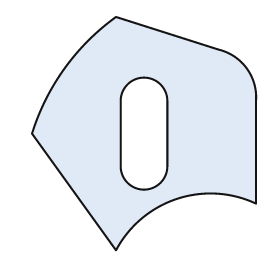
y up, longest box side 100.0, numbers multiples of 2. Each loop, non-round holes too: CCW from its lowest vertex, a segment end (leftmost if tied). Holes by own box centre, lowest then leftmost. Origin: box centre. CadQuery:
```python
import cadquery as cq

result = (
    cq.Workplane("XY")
    .moveTo(-12.0, -50.0)
    .threePointArc((14.0, -28.0), (48.0, -30.0))
    .lineTo(48.0, 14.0)
    .threePointArc((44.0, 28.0), (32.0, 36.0))
    .lineTo(-12.0, 50.0)
    .threePointArc((-34.0, 28.0), (-48.0, 0.0))
    .close()
    .moveTo(-10.0, -14.0)
    .threePointArc((0.0, -24.0), (10.0, -14.0))
    .lineTo(10.0, 14.0)
    .threePointArc((0.0, 24.0), (-10.0, 14.0))
    .close()
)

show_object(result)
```